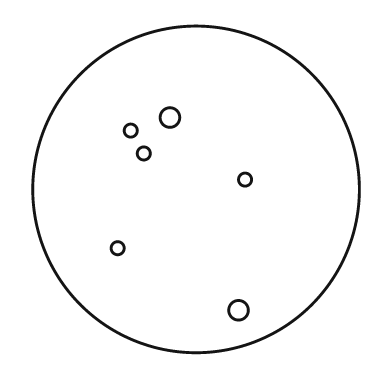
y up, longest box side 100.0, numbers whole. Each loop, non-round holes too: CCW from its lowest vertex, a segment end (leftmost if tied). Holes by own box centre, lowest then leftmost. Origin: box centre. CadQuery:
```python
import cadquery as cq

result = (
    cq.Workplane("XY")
    .moveTo(0.0, 0.0)
    .circle(50.0)
    .moveTo(13.0, -37.0)
    .circle(3.0)
    .moveTo(-24.0, -18.0)
    .circle(2.0)
    .moveTo(15.0, 3.0)
    .circle(2.0)
    .moveTo(-16.0, 11.0)
    .circle(2.0)
    .moveTo(-20.0, 18.0)
    .circle(2.0)
    .moveTo(-8.0, 22.0)
    .circle(3.0)
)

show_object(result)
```